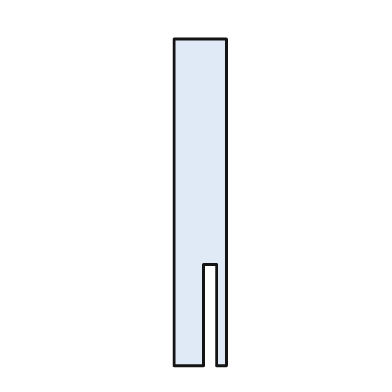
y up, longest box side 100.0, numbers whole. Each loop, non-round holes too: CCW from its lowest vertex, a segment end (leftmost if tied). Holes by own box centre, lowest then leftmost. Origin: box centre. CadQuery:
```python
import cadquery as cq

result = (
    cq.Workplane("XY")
    .moveTo(-8.0, -50.0)
    .lineTo(1.0, -50.0)
    .lineTo(1.0, -19.0)
    .lineTo(5.0, -19.0)
    .lineTo(5.0, -50.0)
    .lineTo(8.0, -50.0)
    .lineTo(8.0, 50.0)
    .lineTo(-8.0, 50.0)
    .close()
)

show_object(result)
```